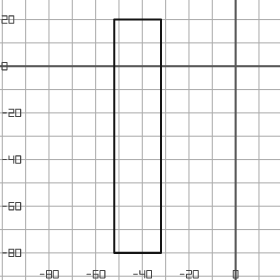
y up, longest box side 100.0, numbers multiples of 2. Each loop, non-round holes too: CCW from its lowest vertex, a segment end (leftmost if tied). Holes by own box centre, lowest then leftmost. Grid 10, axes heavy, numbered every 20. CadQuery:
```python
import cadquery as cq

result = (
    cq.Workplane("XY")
    .moveTo(-52.0, -80.0)
    .lineTo(-32.0, -80.0)
    .lineTo(-32.0, 20.0)
    .lineTo(-52.0, 20.0)
    .close()
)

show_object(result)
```